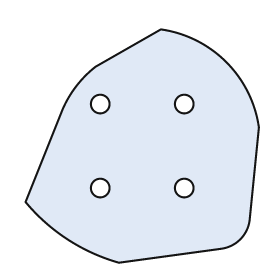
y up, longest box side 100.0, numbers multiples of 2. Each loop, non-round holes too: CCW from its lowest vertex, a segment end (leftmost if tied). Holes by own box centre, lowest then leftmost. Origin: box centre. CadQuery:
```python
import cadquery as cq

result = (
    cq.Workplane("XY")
    .moveTo(-10.0, -50.0)
    .lineTo(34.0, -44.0)
    .threePointArc((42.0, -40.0), (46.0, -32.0))
    .lineTo(50.0, 8.0)
    .threePointArc((36.0, 36.0), (8.0, 50.0))
    .lineTo(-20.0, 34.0)
    .threePointArc((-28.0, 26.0), (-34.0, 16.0))
    .lineTo(-50.0, -24.0)
    .threePointArc((-32.0, -40.0), (-10.0, -50.0))
    .close()
    .moveTo(-18.0, -18.0)
    .circle(4.0)
    .moveTo(18.0, -18.0)
    .circle(4.0)
    .moveTo(-18.0, 18.0)
    .circle(4.0)
    .moveTo(18.0, 18.0)
    .circle(4.0)
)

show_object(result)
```